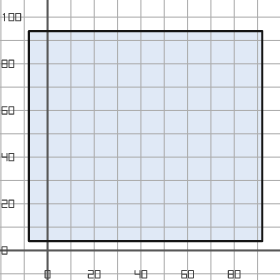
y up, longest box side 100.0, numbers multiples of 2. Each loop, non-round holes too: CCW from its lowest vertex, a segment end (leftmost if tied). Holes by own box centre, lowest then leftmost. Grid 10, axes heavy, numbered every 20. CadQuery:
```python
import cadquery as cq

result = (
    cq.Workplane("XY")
    .moveTo(-8.0, 4.0)
    .lineTo(92.0, 4.0)
    .lineTo(92.0, 94.0)
    .lineTo(-8.0, 94.0)
    .close()
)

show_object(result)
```